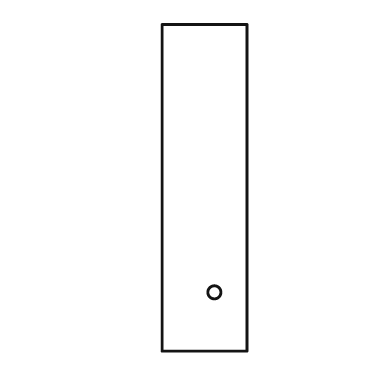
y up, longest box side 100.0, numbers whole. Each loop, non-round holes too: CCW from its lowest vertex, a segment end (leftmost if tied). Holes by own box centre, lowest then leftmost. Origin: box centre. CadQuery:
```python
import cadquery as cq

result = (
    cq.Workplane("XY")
    .moveTo(-13.0, -50.0)
    .lineTo(13.0, -50.0)
    .lineTo(13.0, 50.0)
    .lineTo(-13.0, 50.0)
    .close()
    .moveTo(3.0, -32.0)
    .circle(2.0)
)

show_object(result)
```